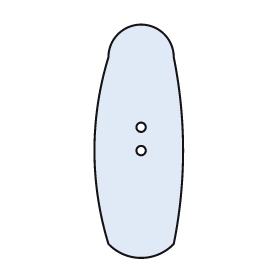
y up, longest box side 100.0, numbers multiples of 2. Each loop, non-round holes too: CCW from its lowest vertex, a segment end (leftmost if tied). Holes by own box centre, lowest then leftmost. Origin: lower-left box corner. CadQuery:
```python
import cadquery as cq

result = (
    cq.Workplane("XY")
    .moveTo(6.0, 6.0)
    .threePointArc((20.0, 0.0), (34.0, 6.0))
    .threePointArc((38.0, 46.0), (34.0, 86.0))
    .threePointArc((20.0, 100.0), (6.0, 86.0))
    .threePointArc((0.0, 46.0), (6.0, 6.0))
    .close()
    .moveTo(20.0, 46.0)
    .circle(2.0)
    .moveTo(20.0, 56.0)
    .circle(2.0)
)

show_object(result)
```